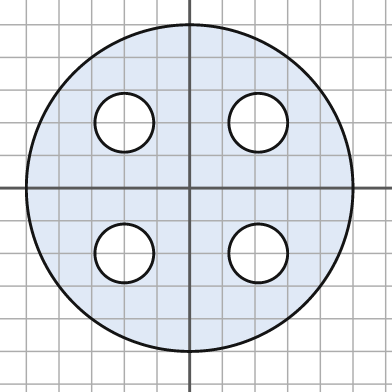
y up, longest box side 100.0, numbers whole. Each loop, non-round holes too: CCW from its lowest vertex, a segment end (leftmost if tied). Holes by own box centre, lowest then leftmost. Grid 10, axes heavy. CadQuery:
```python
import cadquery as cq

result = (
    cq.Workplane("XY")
    .moveTo(0.0, 0.0)
    .circle(50.0)
    .moveTo(-20.0, -20.0)
    .circle(9.0)
    .moveTo(21.0, -20.0)
    .circle(9.0)
    .moveTo(-20.0, 20.0)
    .circle(9.0)
    .moveTo(21.0, 20.0)
    .circle(9.0)
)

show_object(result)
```